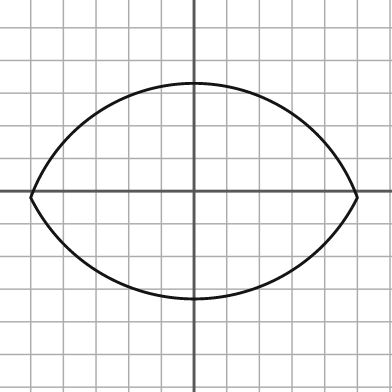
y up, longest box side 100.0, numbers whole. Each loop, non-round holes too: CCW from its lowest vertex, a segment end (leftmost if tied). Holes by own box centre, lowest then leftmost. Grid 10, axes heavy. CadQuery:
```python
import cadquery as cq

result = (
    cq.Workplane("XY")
    .moveTo(-50.0, -2.0)
    .threePointArc((0.0, -33.0), (50.0, -2.0))
    .threePointArc((0.0, 33.0), (-50.0, -2.0))
    .close()
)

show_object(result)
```